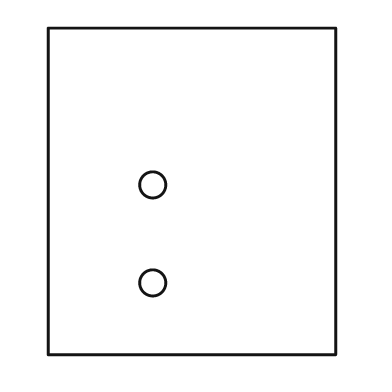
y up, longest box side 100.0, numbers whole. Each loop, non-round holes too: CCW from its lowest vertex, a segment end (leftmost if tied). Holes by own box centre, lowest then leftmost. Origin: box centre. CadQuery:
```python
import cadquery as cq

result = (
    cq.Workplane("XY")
    .moveTo(-44.0, -50.0)
    .lineTo(44.0, -50.0)
    .lineTo(44.0, 50.0)
    .lineTo(-44.0, 50.0)
    .close()
    .moveTo(-12.0, -28.0)
    .circle(4.0)
    .moveTo(-12.0, 2.0)
    .circle(4.0)
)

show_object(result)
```